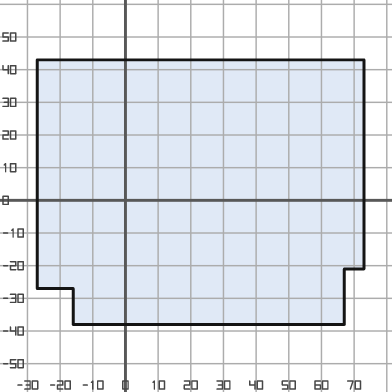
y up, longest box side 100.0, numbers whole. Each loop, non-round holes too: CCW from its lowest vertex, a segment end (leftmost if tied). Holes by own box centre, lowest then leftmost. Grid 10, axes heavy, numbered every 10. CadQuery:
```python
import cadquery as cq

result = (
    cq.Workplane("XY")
    .moveTo(-16.0, -38.0)
    .lineTo(67.0, -38.0)
    .lineTo(67.0, -21.0)
    .lineTo(73.0, -21.0)
    .lineTo(73.0, 43.0)
    .lineTo(-27.0, 43.0)
    .lineTo(-27.0, -27.0)
    .lineTo(-16.0, -27.0)
    .close()
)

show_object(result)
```